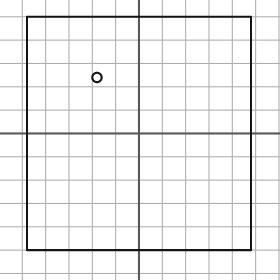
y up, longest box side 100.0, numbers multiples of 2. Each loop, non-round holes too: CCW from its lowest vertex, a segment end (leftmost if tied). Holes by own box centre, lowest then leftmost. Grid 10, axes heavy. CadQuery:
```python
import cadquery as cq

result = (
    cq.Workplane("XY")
    .moveTo(-48.0, -50.0)
    .lineTo(48.0, -50.0)
    .lineTo(48.0, 50.0)
    .lineTo(-48.0, 50.0)
    .close()
    .moveTo(-18.0, 24.0)
    .circle(2.0)
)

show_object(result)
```